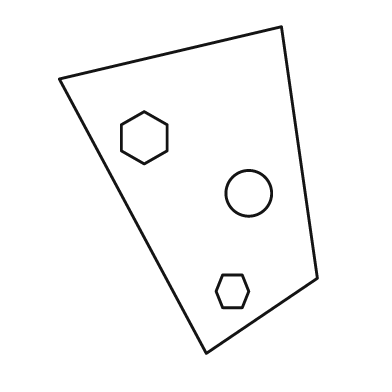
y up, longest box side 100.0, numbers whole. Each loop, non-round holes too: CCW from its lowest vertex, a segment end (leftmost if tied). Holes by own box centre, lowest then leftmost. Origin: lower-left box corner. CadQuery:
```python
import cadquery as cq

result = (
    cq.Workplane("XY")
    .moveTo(45.0, 0.0)
    .lineTo(79.0, 23.0)
    .lineTo(68.0, 100.0)
    .lineTo(0.0, 84.0)
    .close()
    .moveTo(50.0, 14.0)
    .lineTo(56.0, 14.0)
    .lineTo(58.0, 19.0)
    .lineTo(56.0, 24.0)
    .lineTo(50.0, 24.0)
    .lineTo(48.0, 19.0)
    .close()
    .moveTo(58.0, 49.0)
    .circle(7.0)
    .moveTo(26.0, 58.0)
    .lineTo(33.0, 62.0)
    .lineTo(33.0, 70.0)
    .lineTo(26.0, 74.0)
    .lineTo(19.0, 70.0)
    .lineTo(19.0, 62.0)
    .close()
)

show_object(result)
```